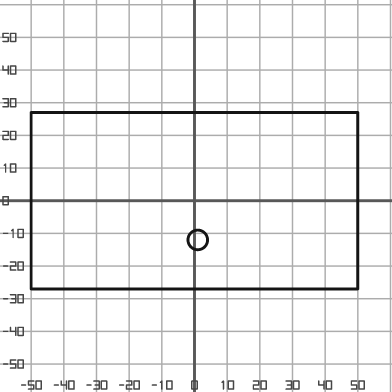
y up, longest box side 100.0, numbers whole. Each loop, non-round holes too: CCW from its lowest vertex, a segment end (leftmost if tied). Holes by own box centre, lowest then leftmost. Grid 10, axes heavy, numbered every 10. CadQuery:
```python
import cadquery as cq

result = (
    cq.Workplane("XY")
    .moveTo(-50.0, -27.0)
    .lineTo(50.0, -27.0)
    .lineTo(50.0, 27.0)
    .lineTo(-50.0, 27.0)
    .close()
    .moveTo(1.0, -12.0)
    .circle(3.0)
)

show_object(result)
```